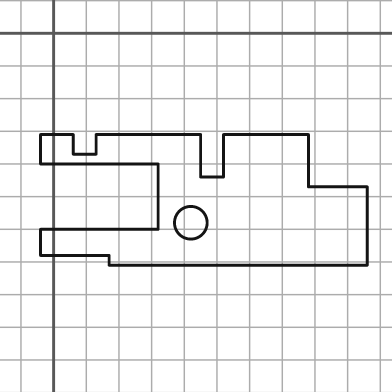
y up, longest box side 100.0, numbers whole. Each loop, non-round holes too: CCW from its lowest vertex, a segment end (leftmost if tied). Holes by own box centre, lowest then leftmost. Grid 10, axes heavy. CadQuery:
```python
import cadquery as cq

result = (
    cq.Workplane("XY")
    .moveTo(17.0, -71.0)
    .lineTo(96.0, -71.0)
    .lineTo(96.0, -47.0)
    .lineTo(78.0, -47.0)
    .lineTo(78.0, -31.0)
    .lineTo(52.0, -31.0)
    .lineTo(52.0, -44.0)
    .lineTo(45.0, -44.0)
    .lineTo(45.0, -31.0)
    .lineTo(13.0, -31.0)
    .lineTo(13.0, -37.0)
    .lineTo(6.0, -37.0)
    .lineTo(6.0, -31.0)
    .lineTo(-4.0, -31.0)
    .lineTo(-4.0, -40.0)
    .lineTo(32.0, -40.0)
    .lineTo(32.0, -60.0)
    .lineTo(-4.0, -60.0)
    .lineTo(-4.0, -68.0)
    .lineTo(17.0, -68.0)
    .close()
    .moveTo(42.0, -58.0)
    .circle(5.0)
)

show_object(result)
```